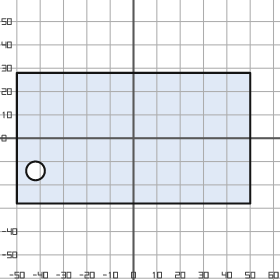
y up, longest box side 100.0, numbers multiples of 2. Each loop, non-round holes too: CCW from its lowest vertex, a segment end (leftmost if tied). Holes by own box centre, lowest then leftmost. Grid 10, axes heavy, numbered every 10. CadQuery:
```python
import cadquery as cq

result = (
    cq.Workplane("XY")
    .moveTo(-50.0, -28.0)
    .lineTo(50.0, -28.0)
    .lineTo(50.0, 28.0)
    .lineTo(-50.0, 28.0)
    .close()
    .moveTo(-42.0, -14.0)
    .circle(4.0)
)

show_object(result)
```